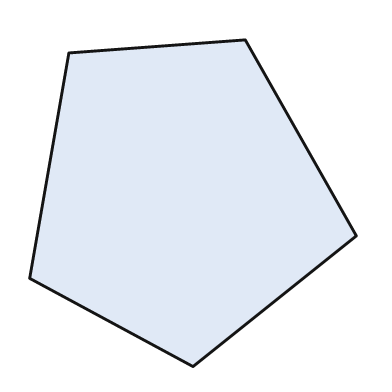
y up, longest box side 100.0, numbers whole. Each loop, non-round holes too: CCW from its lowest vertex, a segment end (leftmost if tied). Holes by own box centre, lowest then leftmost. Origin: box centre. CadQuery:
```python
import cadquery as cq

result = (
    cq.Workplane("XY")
    .moveTo(0.0, -50.0)
    .lineTo(50.0, -10.0)
    .lineTo(16.0, 50.0)
    .lineTo(-38.0, 46.0)
    .lineTo(-50.0, -23.0)
    .close()
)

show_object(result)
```